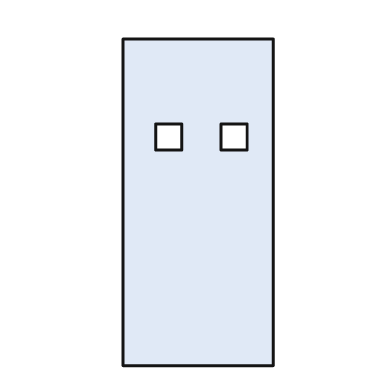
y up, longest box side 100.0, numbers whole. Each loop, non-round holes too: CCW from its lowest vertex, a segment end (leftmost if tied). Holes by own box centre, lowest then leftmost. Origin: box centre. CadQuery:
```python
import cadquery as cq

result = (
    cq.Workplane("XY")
    .moveTo(-23.0, -50.0)
    .lineTo(23.0, -50.0)
    .lineTo(23.0, 50.0)
    .lineTo(-23.0, 50.0)
    .close()
    .moveTo(-13.0, 16.0)
    .lineTo(-5.0, 16.0)
    .lineTo(-5.0, 24.0)
    .lineTo(-13.0, 24.0)
    .close()
    .moveTo(7.0, 16.0)
    .lineTo(15.0, 16.0)
    .lineTo(15.0, 24.0)
    .lineTo(7.0, 24.0)
    .close()
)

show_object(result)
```